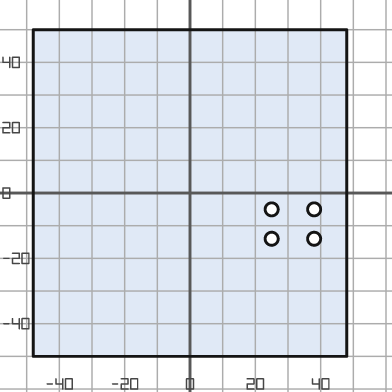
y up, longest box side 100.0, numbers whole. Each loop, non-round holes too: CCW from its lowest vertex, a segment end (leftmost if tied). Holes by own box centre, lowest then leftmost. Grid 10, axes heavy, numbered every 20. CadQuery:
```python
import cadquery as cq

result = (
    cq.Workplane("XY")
    .moveTo(-48.0, -50.0)
    .lineTo(48.0, -50.0)
    .lineTo(48.0, 50.0)
    .lineTo(-48.0, 50.0)
    .close()
    .moveTo(25.0, -14.0)
    .circle(2.0)
    .moveTo(38.0, -14.0)
    .circle(2.0)
    .moveTo(25.0, -5.0)
    .circle(2.0)
    .moveTo(38.0, -5.0)
    .circle(2.0)
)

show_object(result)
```